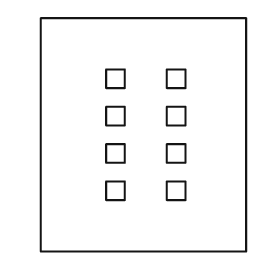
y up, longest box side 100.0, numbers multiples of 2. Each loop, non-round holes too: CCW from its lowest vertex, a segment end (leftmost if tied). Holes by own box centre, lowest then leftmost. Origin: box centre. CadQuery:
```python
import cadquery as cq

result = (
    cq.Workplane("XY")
    .moveTo(-44.0, -50.0)
    .lineTo(44.0, -50.0)
    .lineTo(44.0, 50.0)
    .lineTo(-44.0, 50.0)
    .close()
    .moveTo(-16.0, -28.0)
    .lineTo(-8.0, -28.0)
    .lineTo(-8.0, -20.0)
    .lineTo(-16.0, -20.0)
    .close()
    .moveTo(10.0, -28.0)
    .lineTo(18.0, -28.0)
    .lineTo(18.0, -20.0)
    .lineTo(10.0, -20.0)
    .close()
    .moveTo(-16.0, -12.0)
    .lineTo(-8.0, -12.0)
    .lineTo(-8.0, -4.0)
    .lineTo(-16.0, -4.0)
    .close()
    .moveTo(10.0, -12.0)
    .lineTo(18.0, -12.0)
    .lineTo(18.0, -4.0)
    .lineTo(10.0, -4.0)
    .close()
    .moveTo(-16.0, 4.0)
    .lineTo(-8.0, 4.0)
    .lineTo(-8.0, 12.0)
    .lineTo(-16.0, 12.0)
    .close()
    .moveTo(10.0, 4.0)
    .lineTo(18.0, 4.0)
    .lineTo(18.0, 12.0)
    .lineTo(10.0, 12.0)
    .close()
    .moveTo(-16.0, 20.0)
    .lineTo(-8.0, 20.0)
    .lineTo(-8.0, 28.0)
    .lineTo(-16.0, 28.0)
    .close()
    .moveTo(10.0, 20.0)
    .lineTo(18.0, 20.0)
    .lineTo(18.0, 28.0)
    .lineTo(10.0, 28.0)
    .close()
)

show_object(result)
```